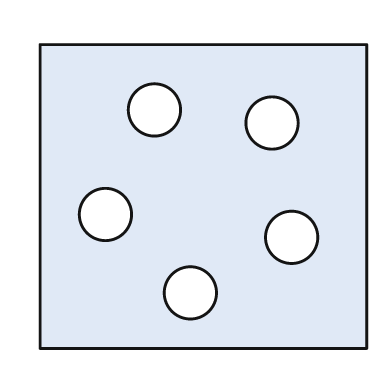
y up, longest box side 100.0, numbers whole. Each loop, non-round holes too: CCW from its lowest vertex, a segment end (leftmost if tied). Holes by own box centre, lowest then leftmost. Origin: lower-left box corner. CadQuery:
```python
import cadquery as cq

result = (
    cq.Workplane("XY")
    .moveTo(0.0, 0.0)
    .lineTo(100.0, 0.0)
    .lineTo(100.0, 93.0)
    .lineTo(0.0, 93.0)
    .close()
    .moveTo(46.0, 17.0)
    .circle(8.0)
    .moveTo(77.0, 34.0)
    .circle(8.0)
    .moveTo(20.0, 41.0)
    .circle(8.0)
    .moveTo(71.0, 69.0)
    .circle(8.0)
    .moveTo(35.0, 73.0)
    .circle(8.0)
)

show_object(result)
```